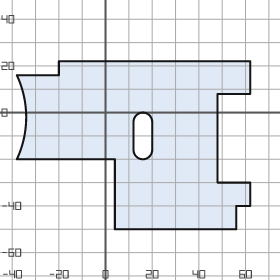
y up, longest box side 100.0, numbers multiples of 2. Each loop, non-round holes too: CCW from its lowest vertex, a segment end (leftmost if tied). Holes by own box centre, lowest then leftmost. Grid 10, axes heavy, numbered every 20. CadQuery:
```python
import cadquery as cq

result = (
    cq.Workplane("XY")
    .moveTo(4.0, -50.0)
    .lineTo(56.0, -50.0)
    .lineTo(56.0, -40.0)
    .lineTo(62.0, -40.0)
    .lineTo(62.0, -30.0)
    .lineTo(48.0, -30.0)
    .lineTo(48.0, 8.0)
    .lineTo(62.0, 8.0)
    .lineTo(62.0, 22.0)
    .lineTo(-20.0, 22.0)
    .lineTo(-20.0, 16.0)
    .lineTo(-38.0, 16.0)
    .threePointArc((-34.0, -2.0), (-38.0, -20.0))
    .lineTo(4.0, -20.0)
    .close()
    .moveTo(12.0, -16.0)
    .threePointArc((16.0, -20.0), (20.0, -16.0))
    .lineTo(20.0, -4.0)
    .threePointArc((16.0, 0.0), (12.0, -4.0))
    .close()
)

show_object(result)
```